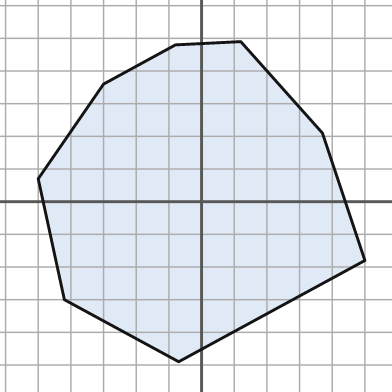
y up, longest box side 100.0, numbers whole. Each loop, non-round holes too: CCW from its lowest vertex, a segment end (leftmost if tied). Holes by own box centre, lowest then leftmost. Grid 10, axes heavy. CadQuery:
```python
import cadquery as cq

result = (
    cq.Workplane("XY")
    .moveTo(-7.0, -49.0)
    .lineTo(50.0, -18.0)
    .lineTo(37.0, 21.0)
    .lineTo(12.0, 49.0)
    .lineTo(-8.0, 48.0)
    .lineTo(-30.0, 36.0)
    .lineTo(-50.0, 7.0)
    .lineTo(-42.0, -30.0)
    .close()
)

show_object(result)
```